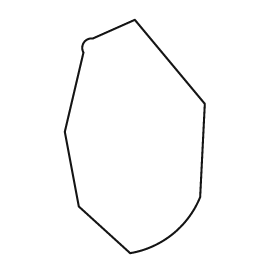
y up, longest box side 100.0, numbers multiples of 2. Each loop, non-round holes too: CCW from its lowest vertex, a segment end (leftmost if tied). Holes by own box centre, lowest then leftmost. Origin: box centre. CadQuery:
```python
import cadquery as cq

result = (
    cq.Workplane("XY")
    .moveTo(-2.0, -50.0)
    .threePointArc((16.0, -42.0), (28.0, -26.0))
    .lineTo(30.0, 14.0)
    .lineTo(0.0, 50.0)
    .lineTo(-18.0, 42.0)
    .threePointArc((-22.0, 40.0), (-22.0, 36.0))
    .lineTo(-30.0, 2.0)
    .lineTo(-24.0, -30.0)
    .close()
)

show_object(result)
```